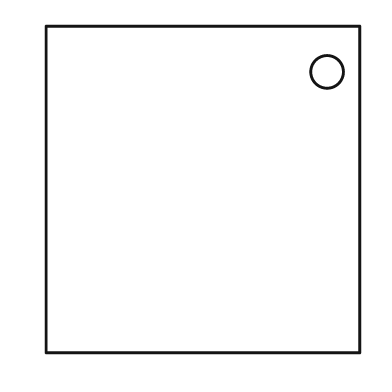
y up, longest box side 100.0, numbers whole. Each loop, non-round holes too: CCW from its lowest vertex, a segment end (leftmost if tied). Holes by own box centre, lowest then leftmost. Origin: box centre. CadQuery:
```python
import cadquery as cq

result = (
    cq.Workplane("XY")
    .moveTo(-48.0, -50.0)
    .lineTo(48.0, -50.0)
    .lineTo(48.0, 50.0)
    .lineTo(-48.0, 50.0)
    .close()
    .moveTo(38.0, 36.0)
    .circle(5.0)
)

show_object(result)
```